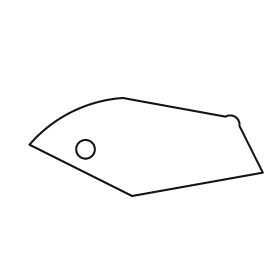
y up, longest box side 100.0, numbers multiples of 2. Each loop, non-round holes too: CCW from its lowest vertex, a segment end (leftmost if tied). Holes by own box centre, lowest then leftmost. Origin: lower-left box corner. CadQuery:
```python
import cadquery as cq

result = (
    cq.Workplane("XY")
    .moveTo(44.0, 0.0)
    .lineTo(100.0, 10.0)
    .lineTo(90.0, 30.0)
    .threePointArc((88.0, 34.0), (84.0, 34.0))
    .lineTo(40.0, 42.0)
    .threePointArc((18.0, 36.0), (0.0, 22.0))
    .close()
    .moveTo(24.0, 20.0)
    .circle(4.0)
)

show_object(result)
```